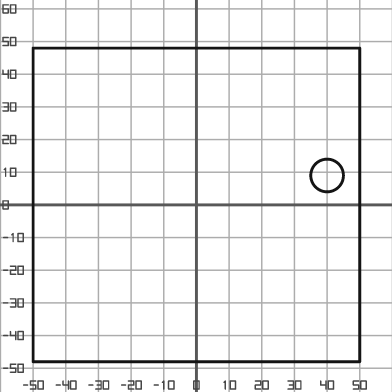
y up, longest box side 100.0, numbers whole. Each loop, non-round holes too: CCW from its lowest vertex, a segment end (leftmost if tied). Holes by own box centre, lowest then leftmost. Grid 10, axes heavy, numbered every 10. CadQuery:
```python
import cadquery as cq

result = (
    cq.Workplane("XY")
    .moveTo(-50.0, -48.0)
    .lineTo(50.0, -48.0)
    .lineTo(50.0, 48.0)
    .lineTo(-50.0, 48.0)
    .close()
    .moveTo(40.0, 9.0)
    .circle(5.0)
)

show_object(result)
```